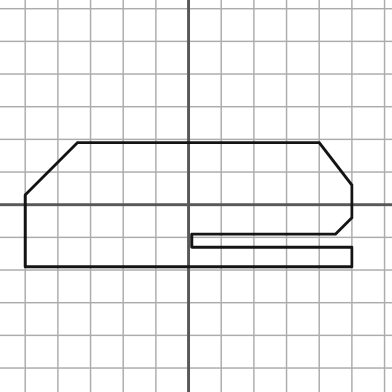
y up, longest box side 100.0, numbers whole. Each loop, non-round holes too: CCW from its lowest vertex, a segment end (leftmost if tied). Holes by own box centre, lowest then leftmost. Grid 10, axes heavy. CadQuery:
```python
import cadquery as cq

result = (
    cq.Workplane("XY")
    .moveTo(-50.0, -19.0)
    .lineTo(50.0, -19.0)
    .lineTo(50.0, -13.0)
    .lineTo(1.0, -13.0)
    .lineTo(1.0, -9.0)
    .lineTo(45.0, -9.0)
    .lineTo(50.0, -4.0)
    .lineTo(50.0, 6.0)
    .lineTo(40.0, 19.0)
    .lineTo(-34.0, 19.0)
    .lineTo(-50.0, 3.0)
    .close()
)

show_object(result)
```